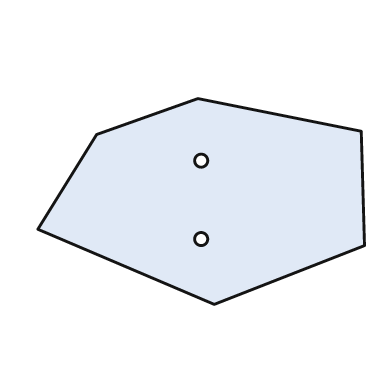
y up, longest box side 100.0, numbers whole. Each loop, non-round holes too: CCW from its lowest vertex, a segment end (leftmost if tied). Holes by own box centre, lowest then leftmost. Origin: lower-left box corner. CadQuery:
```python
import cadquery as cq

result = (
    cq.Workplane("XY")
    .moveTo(54.0, 0.0)
    .lineTo(100.0, 18.0)
    .lineTo(99.0, 53.0)
    .lineTo(49.0, 63.0)
    .lineTo(18.0, 52.0)
    .lineTo(0.0, 23.0)
    .close()
    .moveTo(50.0, 20.0)
    .circle(2.0)
    .moveTo(50.0, 44.0)
    .circle(2.0)
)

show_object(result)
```